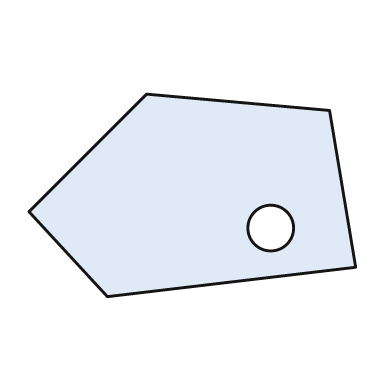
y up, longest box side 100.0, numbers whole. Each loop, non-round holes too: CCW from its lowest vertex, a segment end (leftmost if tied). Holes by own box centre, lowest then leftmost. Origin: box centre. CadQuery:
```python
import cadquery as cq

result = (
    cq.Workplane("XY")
    .moveTo(-26.0, -31.0)
    .lineTo(50.0, -22.0)
    .lineTo(42.0, 26.0)
    .lineTo(-14.0, 31.0)
    .lineTo(-50.0, -5.0)
    .close()
    .moveTo(24.0, -10.0)
    .circle(7.0)
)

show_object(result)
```